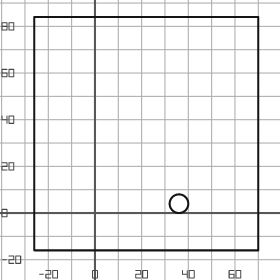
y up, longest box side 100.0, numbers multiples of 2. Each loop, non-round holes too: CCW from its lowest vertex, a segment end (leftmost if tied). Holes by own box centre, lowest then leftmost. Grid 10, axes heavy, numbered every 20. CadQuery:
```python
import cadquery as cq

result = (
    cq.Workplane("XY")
    .moveTo(-26.0, -16.0)
    .lineTo(70.0, -16.0)
    .lineTo(70.0, 84.0)
    .lineTo(-26.0, 84.0)
    .close()
    .moveTo(36.0, 4.0)
    .circle(4.0)
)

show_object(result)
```